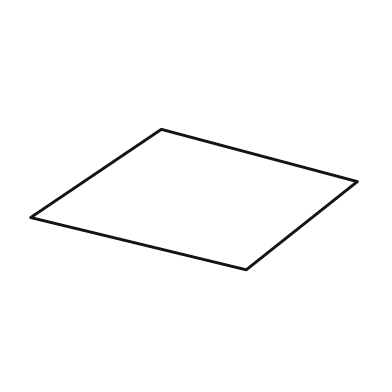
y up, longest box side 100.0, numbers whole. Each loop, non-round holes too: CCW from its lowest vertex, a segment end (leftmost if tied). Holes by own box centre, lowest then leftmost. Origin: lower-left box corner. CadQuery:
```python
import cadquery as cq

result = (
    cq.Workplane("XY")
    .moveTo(66.0, 0.0)
    .lineTo(100.0, 27.0)
    .lineTo(40.0, 43.0)
    .lineTo(0.0, 16.0)
    .close()
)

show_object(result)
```